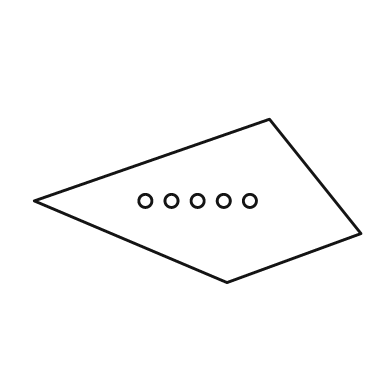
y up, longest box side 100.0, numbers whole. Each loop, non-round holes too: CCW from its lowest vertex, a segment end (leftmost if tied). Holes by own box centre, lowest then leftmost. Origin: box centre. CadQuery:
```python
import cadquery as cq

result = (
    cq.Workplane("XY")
    .moveTo(9.0, -25.0)
    .lineTo(50.0, -10.0)
    .lineTo(22.0, 25.0)
    .lineTo(-50.0, 0.0)
    .close()
    .moveTo(-16.0, 0.0)
    .circle(2.0)
    .moveTo(-8.0, 0.0)
    .circle(2.0)
    .moveTo(0.0, 0.0)
    .circle(2.0)
    .moveTo(8.0, 0.0)
    .circle(2.0)
    .moveTo(16.0, 0.0)
    .circle(2.0)
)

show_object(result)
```